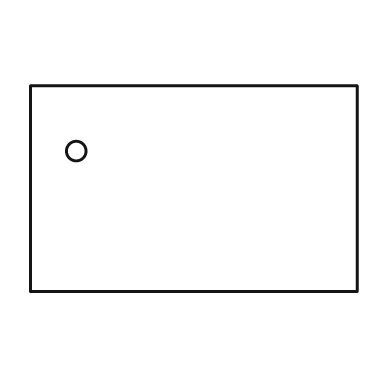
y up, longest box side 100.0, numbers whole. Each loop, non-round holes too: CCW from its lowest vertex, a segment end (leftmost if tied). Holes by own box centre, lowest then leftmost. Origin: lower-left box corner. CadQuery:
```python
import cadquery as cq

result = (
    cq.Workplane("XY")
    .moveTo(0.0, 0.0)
    .lineTo(100.0, 0.0)
    .lineTo(100.0, 63.0)
    .lineTo(0.0, 63.0)
    .close()
    .moveTo(14.0, 43.0)
    .circle(3.0)
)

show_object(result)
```